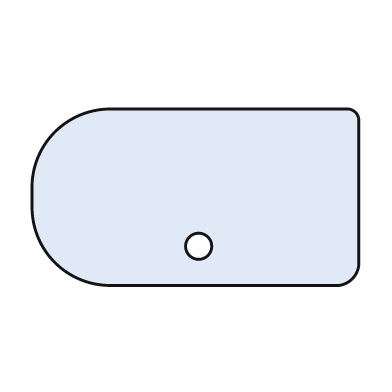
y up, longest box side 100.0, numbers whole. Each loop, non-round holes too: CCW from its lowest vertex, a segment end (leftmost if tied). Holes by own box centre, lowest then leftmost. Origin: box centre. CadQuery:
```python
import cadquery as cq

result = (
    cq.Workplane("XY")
    .moveTo(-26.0, -27.0)
    .lineTo(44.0, -27.0)
    .threePointArc((48.0, -25.0), (50.0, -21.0))
    .lineTo(50.0, 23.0)
    .threePointArc((49.0, 26.0), (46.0, 27.0))
    .lineTo(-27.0, 27.0)
    .threePointArc((-43.0, 20.0), (-50.0, 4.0))
    .lineTo(-50.0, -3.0)
    .threePointArc((-43.0, -20.0), (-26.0, -27.0))
    .close()
    .moveTo(1.0, -15.0)
    .circle(4.0)
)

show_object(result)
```